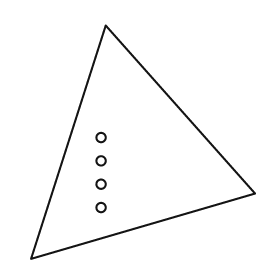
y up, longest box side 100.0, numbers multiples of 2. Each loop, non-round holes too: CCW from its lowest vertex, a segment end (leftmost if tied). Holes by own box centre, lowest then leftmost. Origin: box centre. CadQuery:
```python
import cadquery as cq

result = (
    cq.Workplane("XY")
    .moveTo(-48.0, -50.0)
    .lineTo(48.0, -22.0)
    .lineTo(-16.0, 50.0)
    .close()
    .moveTo(-18.0, -28.0)
    .circle(2.0)
    .moveTo(-18.0, -18.0)
    .circle(2.0)
    .moveTo(-18.0, -8.0)
    .circle(2.0)
    .moveTo(-18.0, 2.0)
    .circle(2.0)
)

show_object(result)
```